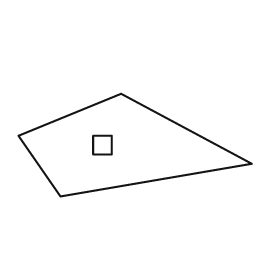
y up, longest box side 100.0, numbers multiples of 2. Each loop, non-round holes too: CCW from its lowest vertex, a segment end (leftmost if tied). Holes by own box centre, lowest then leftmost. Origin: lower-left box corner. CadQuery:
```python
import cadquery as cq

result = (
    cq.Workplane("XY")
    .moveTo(18.0, 0.0)
    .lineTo(100.0, 14.0)
    .lineTo(44.0, 44.0)
    .lineTo(0.0, 26.0)
    .close()
    .moveTo(32.0, 18.0)
    .lineTo(40.0, 18.0)
    .lineTo(40.0, 26.0)
    .lineTo(32.0, 26.0)
    .close()
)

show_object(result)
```